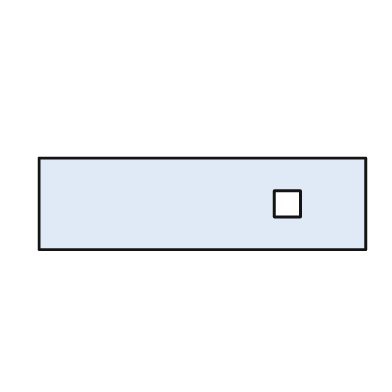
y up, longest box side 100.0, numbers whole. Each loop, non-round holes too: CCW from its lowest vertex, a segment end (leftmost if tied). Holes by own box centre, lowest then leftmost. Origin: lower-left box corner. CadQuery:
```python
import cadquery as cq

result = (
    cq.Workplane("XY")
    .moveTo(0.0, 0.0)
    .lineTo(100.0, 0.0)
    .lineTo(100.0, 28.0)
    .lineTo(0.0, 28.0)
    .close()
    .moveTo(72.0, 10.0)
    .lineTo(80.0, 10.0)
    .lineTo(80.0, 18.0)
    .lineTo(72.0, 18.0)
    .close()
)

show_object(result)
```